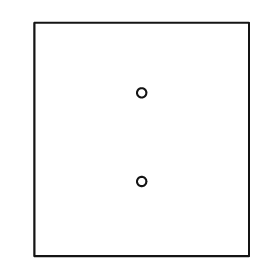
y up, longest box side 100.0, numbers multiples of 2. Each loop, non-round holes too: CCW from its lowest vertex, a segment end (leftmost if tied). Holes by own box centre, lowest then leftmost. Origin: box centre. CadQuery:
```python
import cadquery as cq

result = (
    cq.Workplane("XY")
    .moveTo(-46.0, -50.0)
    .lineTo(46.0, -50.0)
    .lineTo(46.0, 50.0)
    .lineTo(-46.0, 50.0)
    .close()
    .moveTo(0.0, -18.0)
    .circle(2.0)
    .moveTo(0.0, 20.0)
    .circle(2.0)
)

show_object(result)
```